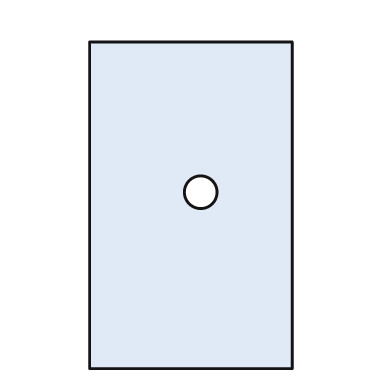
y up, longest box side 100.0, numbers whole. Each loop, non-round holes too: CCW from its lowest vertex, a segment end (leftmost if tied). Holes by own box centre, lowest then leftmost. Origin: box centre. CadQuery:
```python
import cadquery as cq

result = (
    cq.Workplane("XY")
    .moveTo(-31.0, -50.0)
    .lineTo(31.0, -50.0)
    .lineTo(31.0, 50.0)
    .lineTo(-31.0, 50.0)
    .close()
    .moveTo(3.0, 4.0)
    .circle(5.0)
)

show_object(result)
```